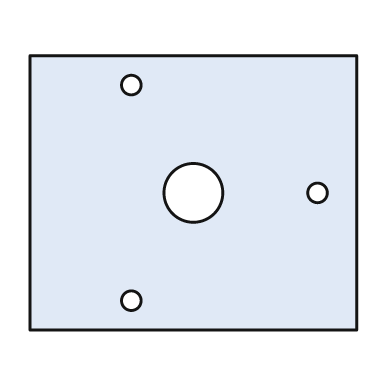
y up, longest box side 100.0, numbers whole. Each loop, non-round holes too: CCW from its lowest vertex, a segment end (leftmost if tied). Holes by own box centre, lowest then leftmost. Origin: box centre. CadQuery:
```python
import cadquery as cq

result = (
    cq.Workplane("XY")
    .moveTo(-50.0, -42.0)
    .lineTo(50.0, -42.0)
    .lineTo(50.0, 42.0)
    .lineTo(-50.0, 42.0)
    .close()
    .moveTo(-19.0, -33.0)
    .circle(3.0)
    .moveTo(0.0, 0.0)
    .circle(9.0)
    .moveTo(38.0, 0.0)
    .circle(3.0)
    .moveTo(-19.0, 33.0)
    .circle(3.0)
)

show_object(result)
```